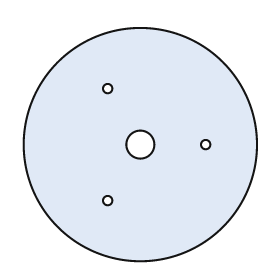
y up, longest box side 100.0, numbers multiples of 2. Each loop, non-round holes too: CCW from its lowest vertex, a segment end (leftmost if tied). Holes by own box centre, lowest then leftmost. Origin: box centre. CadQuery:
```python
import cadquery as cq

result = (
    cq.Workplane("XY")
    .moveTo(0.0, 0.0)
    .circle(50.0)
    .moveTo(-14.0, -24.0)
    .circle(2.0)
    .moveTo(0.0, 0.0)
    .circle(6.0)
    .moveTo(28.0, 0.0)
    .circle(2.0)
    .moveTo(-14.0, 24.0)
    .circle(2.0)
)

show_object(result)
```